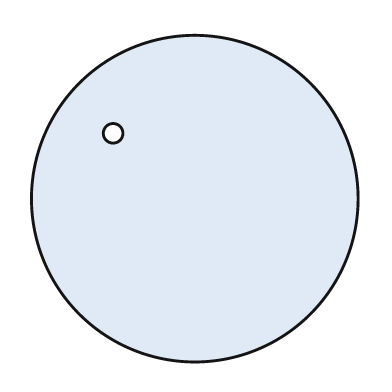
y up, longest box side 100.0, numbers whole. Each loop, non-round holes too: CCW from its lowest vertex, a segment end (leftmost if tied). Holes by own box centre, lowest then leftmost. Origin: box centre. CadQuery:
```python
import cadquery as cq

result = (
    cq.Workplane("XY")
    .moveTo(0.0, 0.0)
    .circle(50.0)
    .moveTo(-25.0, 20.0)
    .circle(3.0)
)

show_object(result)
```